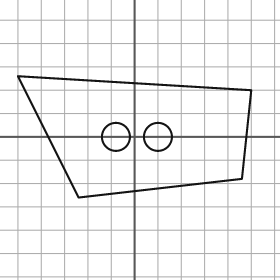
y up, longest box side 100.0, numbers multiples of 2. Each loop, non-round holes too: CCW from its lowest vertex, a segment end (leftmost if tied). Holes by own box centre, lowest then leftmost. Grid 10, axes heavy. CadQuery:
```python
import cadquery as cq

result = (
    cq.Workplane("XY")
    .moveTo(-24.0, -26.0)
    .lineTo(46.0, -18.0)
    .lineTo(50.0, 20.0)
    .lineTo(-50.0, 26.0)
    .close()
    .moveTo(-8.0, 0.0)
    .circle(6.0)
    .moveTo(10.0, 0.0)
    .circle(6.0)
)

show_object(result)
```